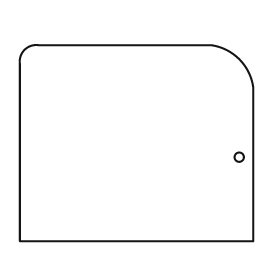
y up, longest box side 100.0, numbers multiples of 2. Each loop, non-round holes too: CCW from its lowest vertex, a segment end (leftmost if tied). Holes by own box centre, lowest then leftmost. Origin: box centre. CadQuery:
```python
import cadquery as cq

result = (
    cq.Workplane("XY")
    .moveTo(-50.0, -42.0)
    .lineTo(50.0, -42.0)
    .lineTo(50.0, 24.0)
    .threePointArc((44.0, 36.0), (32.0, 42.0))
    .lineTo(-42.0, 42.0)
    .threePointArc((-48.0, 40.0), (-50.0, 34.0))
    .close()
    .moveTo(44.0, -6.0)
    .circle(2.0)
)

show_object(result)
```